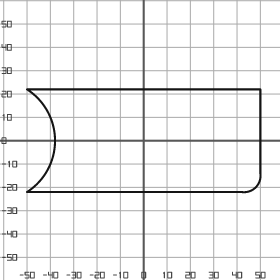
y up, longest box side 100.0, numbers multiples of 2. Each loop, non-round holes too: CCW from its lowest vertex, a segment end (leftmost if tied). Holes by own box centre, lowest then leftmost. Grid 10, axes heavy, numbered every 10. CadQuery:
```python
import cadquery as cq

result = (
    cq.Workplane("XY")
    .moveTo(-50.0, -22.0)
    .lineTo(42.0, -22.0)
    .threePointArc((48.0, -20.0), (50.0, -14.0))
    .lineTo(50.0, 22.0)
    .lineTo(-50.0, 22.0)
    .threePointArc((-38.0, 0.0), (-50.0, -22.0))
    .close()
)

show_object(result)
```